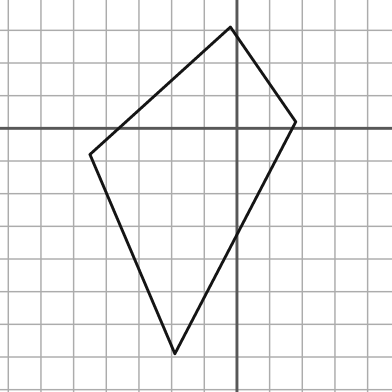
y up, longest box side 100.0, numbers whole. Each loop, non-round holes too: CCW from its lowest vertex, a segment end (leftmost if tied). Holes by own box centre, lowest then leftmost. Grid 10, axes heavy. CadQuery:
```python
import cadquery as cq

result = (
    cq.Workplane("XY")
    .moveTo(-19.0, -69.0)
    .lineTo(18.0, 2.0)
    .lineTo(-2.0, 31.0)
    .lineTo(-45.0, -8.0)
    .close()
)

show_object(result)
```